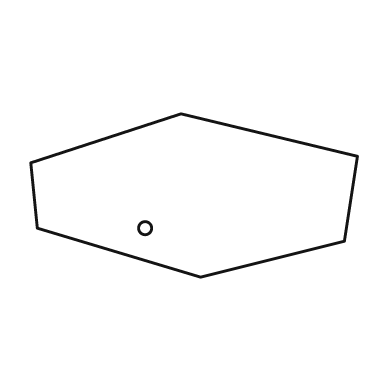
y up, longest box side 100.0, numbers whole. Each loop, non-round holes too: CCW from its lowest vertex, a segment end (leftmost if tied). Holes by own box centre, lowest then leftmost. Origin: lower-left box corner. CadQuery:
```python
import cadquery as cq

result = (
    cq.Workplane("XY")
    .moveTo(52.0, 0.0)
    .lineTo(96.0, 11.0)
    .lineTo(100.0, 37.0)
    .lineTo(46.0, 50.0)
    .lineTo(0.0, 35.0)
    .lineTo(2.0, 15.0)
    .close()
    .moveTo(35.0, 15.0)
    .circle(2.0)
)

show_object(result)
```